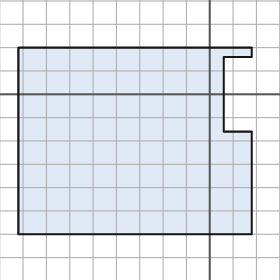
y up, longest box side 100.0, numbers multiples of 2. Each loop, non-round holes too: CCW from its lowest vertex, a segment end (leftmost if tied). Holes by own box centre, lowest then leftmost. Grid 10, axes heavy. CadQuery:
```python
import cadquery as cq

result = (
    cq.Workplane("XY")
    .moveTo(-82.0, -60.0)
    .lineTo(18.0, -60.0)
    .lineTo(18.0, -16.0)
    .lineTo(6.0, -16.0)
    .lineTo(6.0, 16.0)
    .lineTo(18.0, 16.0)
    .lineTo(18.0, 20.0)
    .lineTo(-82.0, 20.0)
    .close()
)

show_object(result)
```